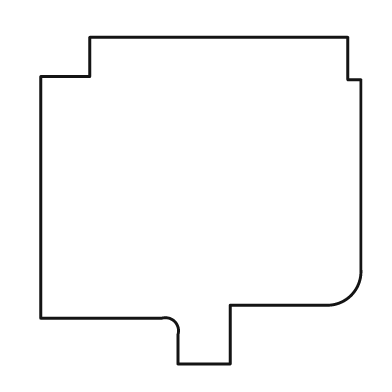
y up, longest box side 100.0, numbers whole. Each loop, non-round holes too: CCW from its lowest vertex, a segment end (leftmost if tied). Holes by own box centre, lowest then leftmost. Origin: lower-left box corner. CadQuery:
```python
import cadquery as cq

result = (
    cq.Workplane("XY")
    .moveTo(42.0, 0.0)
    .lineTo(58.0, 0.0)
    .lineTo(58.0, 18.0)
    .lineTo(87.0, 18.0)
    .threePointArc((95.0, 21.0), (98.0, 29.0))
    .lineTo(98.0, 87.0)
    .lineTo(94.0, 87.0)
    .lineTo(94.0, 100.0)
    .lineTo(15.0, 100.0)
    .lineTo(15.0, 88.0)
    .lineTo(0.0, 88.0)
    .lineTo(0.0, 14.0)
    .lineTo(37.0, 14.0)
    .threePointArc((41.0, 13.0), (42.0, 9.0))
    .close()
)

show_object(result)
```